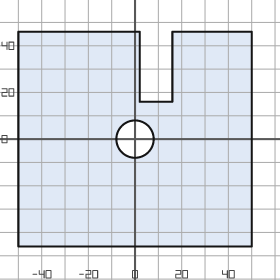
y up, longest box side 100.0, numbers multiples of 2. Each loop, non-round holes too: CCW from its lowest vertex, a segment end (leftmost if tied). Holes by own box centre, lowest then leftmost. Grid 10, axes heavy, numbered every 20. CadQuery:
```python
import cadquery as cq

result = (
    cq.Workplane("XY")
    .moveTo(-50.0, -46.0)
    .lineTo(50.0, -46.0)
    .lineTo(50.0, 46.0)
    .lineTo(16.0, 46.0)
    .lineTo(16.0, 16.0)
    .lineTo(2.0, 16.0)
    .lineTo(2.0, 46.0)
    .lineTo(-50.0, 46.0)
    .close()
    .moveTo(0.0, 0.0)
    .circle(8.0)
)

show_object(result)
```